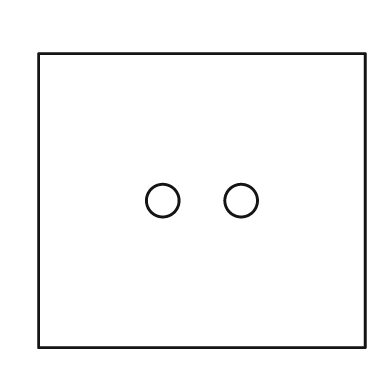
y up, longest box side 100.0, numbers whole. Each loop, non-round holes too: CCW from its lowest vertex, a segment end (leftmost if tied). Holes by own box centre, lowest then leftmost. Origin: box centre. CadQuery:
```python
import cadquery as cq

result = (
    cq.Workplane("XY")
    .moveTo(-50.0, -45.0)
    .lineTo(50.0, -45.0)
    .lineTo(50.0, 45.0)
    .lineTo(-50.0, 45.0)
    .close()
    .moveTo(-12.0, 0.0)
    .circle(5.0)
    .moveTo(12.0, 0.0)
    .circle(5.0)
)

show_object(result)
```